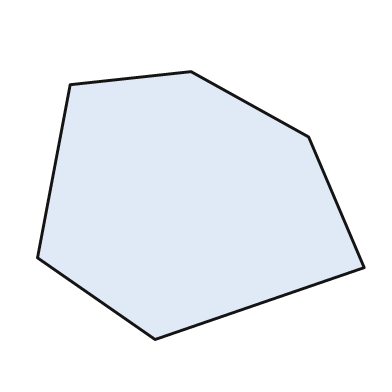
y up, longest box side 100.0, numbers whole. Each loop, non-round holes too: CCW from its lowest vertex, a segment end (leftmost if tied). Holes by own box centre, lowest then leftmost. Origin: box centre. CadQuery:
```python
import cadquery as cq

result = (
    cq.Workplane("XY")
    .moveTo(-14.0, -41.0)
    .lineTo(50.0, -19.0)
    .lineTo(33.0, 21.0)
    .lineTo(-3.0, 41.0)
    .lineTo(-40.0, 37.0)
    .lineTo(-50.0, -16.0)
    .close()
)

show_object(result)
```